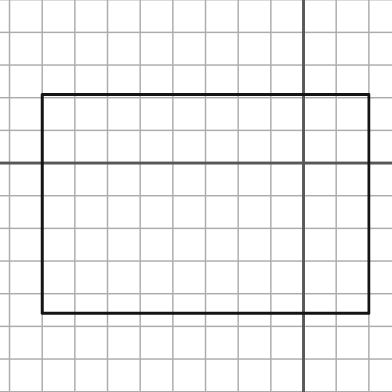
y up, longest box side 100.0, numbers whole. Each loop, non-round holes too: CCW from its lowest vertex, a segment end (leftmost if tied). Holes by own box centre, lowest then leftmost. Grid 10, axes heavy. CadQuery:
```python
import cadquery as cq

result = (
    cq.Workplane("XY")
    .moveTo(-80.0, -46.0)
    .lineTo(20.0, -46.0)
    .lineTo(20.0, 21.0)
    .lineTo(-80.0, 21.0)
    .close()
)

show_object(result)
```